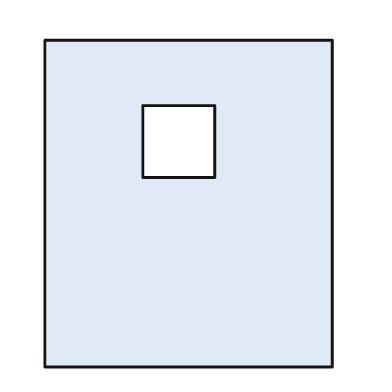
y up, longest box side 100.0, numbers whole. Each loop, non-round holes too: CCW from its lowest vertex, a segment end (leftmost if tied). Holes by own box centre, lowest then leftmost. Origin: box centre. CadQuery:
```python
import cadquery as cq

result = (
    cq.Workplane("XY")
    .moveTo(-44.0, -50.0)
    .lineTo(44.0, -50.0)
    .lineTo(44.0, 50.0)
    .lineTo(-44.0, 50.0)
    .close()
    .moveTo(-14.0, 8.0)
    .lineTo(8.0, 8.0)
    .lineTo(8.0, 30.0)
    .lineTo(-14.0, 30.0)
    .close()
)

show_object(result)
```